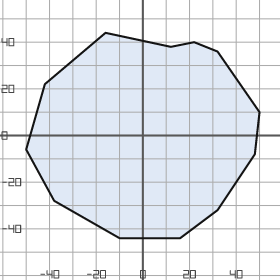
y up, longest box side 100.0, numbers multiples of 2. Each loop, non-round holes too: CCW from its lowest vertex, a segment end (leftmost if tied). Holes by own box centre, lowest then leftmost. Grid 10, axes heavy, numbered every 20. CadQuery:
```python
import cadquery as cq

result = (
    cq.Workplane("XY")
    .moveTo(-10.0, -44.0)
    .lineTo(16.0, -44.0)
    .lineTo(32.0, -32.0)
    .lineTo(48.0, -8.0)
    .lineTo(50.0, 10.0)
    .lineTo(32.0, 36.0)
    .lineTo(22.0, 40.0)
    .lineTo(12.0, 38.0)
    .lineTo(-16.0, 44.0)
    .lineTo(-42.0, 22.0)
    .lineTo(-50.0, -6.0)
    .lineTo(-38.0, -28.0)
    .close()
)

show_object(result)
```